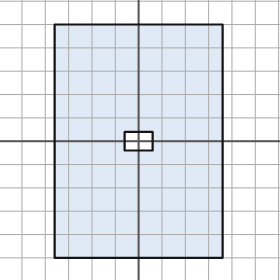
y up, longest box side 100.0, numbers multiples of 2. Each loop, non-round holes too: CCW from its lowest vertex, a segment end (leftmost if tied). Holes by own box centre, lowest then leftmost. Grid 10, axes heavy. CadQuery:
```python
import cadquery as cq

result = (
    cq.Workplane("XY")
    .moveTo(-36.0, -50.0)
    .lineTo(36.0, -50.0)
    .lineTo(36.0, 50.0)
    .lineTo(-36.0, 50.0)
    .close()
    .moveTo(-6.0, -4.0)
    .lineTo(6.0, -4.0)
    .lineTo(6.0, 4.0)
    .lineTo(-6.0, 4.0)
    .close()
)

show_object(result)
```